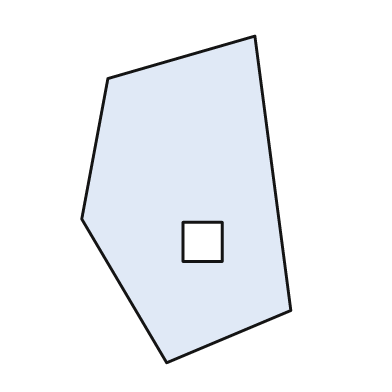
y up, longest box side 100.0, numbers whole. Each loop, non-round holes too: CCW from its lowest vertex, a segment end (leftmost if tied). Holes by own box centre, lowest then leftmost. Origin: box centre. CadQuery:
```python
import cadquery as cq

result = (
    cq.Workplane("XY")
    .moveTo(-6.0, -50.0)
    .lineTo(32.0, -34.0)
    .lineTo(21.0, 50.0)
    .lineTo(-24.0, 37.0)
    .lineTo(-32.0, -6.0)
    .close()
    .moveTo(-1.0, -19.0)
    .lineTo(11.0, -19.0)
    .lineTo(11.0, -7.0)
    .lineTo(-1.0, -7.0)
    .close()
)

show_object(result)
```